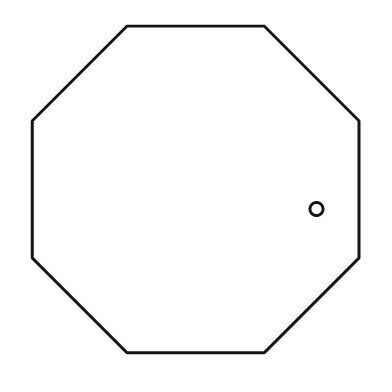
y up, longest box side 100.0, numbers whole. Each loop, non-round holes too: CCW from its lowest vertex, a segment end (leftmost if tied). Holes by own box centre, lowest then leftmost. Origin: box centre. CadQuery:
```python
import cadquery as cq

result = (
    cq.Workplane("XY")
    .moveTo(-21.0, -50.0)
    .lineTo(21.0, -50.0)
    .lineTo(50.0, -21.0)
    .lineTo(50.0, 21.0)
    .lineTo(21.0, 50.0)
    .lineTo(-21.0, 50.0)
    .lineTo(-50.0, 21.0)
    .lineTo(-50.0, -21.0)
    .close()
    .moveTo(37.0, -6.0)
    .circle(2.0)
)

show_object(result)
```